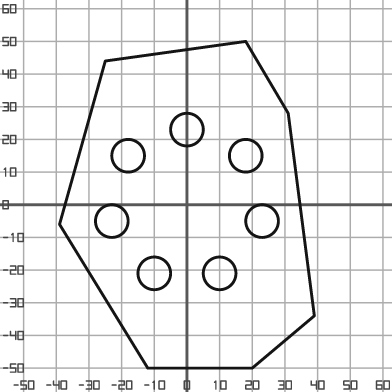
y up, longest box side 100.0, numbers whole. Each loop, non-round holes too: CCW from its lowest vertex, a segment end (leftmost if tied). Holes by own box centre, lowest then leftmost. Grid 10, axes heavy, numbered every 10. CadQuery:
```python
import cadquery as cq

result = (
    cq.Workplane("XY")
    .moveTo(-12.0, -50.0)
    .lineTo(20.0, -50.0)
    .lineTo(39.0, -34.0)
    .lineTo(31.0, 28.0)
    .lineTo(18.0, 50.0)
    .lineTo(-25.0, 44.0)
    .lineTo(-39.0, -6.0)
    .close()
    .moveTo(-10.0, -21.0)
    .circle(5.0)
    .moveTo(10.0, -21.0)
    .circle(5.0)
    .moveTo(-23.0, -5.0)
    .circle(5.0)
    .moveTo(23.0, -5.0)
    .circle(5.0)
    .moveTo(-18.0, 15.0)
    .circle(5.0)
    .moveTo(18.0, 15.0)
    .circle(5.0)
    .moveTo(0.0, 23.0)
    .circle(5.0)
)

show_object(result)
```